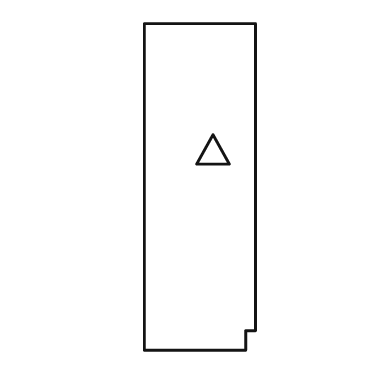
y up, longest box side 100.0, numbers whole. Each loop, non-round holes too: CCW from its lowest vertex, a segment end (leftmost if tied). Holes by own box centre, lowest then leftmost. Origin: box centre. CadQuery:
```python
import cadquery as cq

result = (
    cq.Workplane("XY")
    .moveTo(-17.0, -50.0)
    .lineTo(14.0, -50.0)
    .lineTo(14.0, -44.0)
    .lineTo(17.0, -44.0)
    .lineTo(17.0, 50.0)
    .lineTo(-17.0, 50.0)
    .close()
    .moveTo(-1.0, 7.0)
    .lineTo(9.0, 7.0)
    .lineTo(4.0, 16.0)
    .close()
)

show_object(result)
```